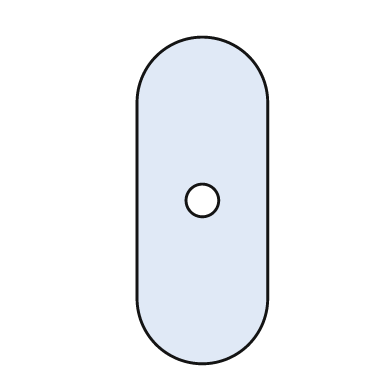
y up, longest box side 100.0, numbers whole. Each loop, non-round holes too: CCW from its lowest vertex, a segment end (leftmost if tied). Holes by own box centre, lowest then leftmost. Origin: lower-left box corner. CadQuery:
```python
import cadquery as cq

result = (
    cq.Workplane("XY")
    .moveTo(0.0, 20.0)
    .threePointArc((20.0, 0.0), (40.0, 20.0))
    .lineTo(40.0, 80.0)
    .threePointArc((20.0, 100.0), (0.0, 80.0))
    .close()
    .moveTo(20.0, 50.0)
    .circle(5.0)
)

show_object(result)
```